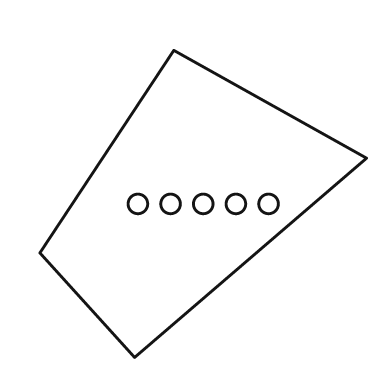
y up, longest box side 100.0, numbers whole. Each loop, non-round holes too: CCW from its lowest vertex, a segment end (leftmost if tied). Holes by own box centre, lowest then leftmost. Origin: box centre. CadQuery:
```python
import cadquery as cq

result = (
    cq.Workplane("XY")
    .moveTo(-21.0, -47.0)
    .lineTo(50.0, 14.0)
    .lineTo(-9.0, 47.0)
    .lineTo(-50.0, -15.0)
    .close()
    .moveTo(-20.0, 0.0)
    .circle(3.0)
    .moveTo(-10.0, 0.0)
    .circle(3.0)
    .moveTo(0.0, 0.0)
    .circle(3.0)
    .moveTo(10.0, 0.0)
    .circle(3.0)
    .moveTo(20.0, 0.0)
    .circle(3.0)
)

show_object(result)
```